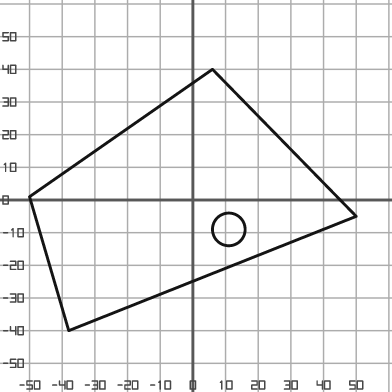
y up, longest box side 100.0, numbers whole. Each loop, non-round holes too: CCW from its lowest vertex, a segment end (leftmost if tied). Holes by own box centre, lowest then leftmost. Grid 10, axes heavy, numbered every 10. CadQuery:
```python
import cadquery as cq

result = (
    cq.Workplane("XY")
    .moveTo(-38.0, -40.0)
    .lineTo(50.0, -5.0)
    .lineTo(6.0, 40.0)
    .lineTo(-50.0, 1.0)
    .close()
    .moveTo(11.0, -9.0)
    .circle(5.0)
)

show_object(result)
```